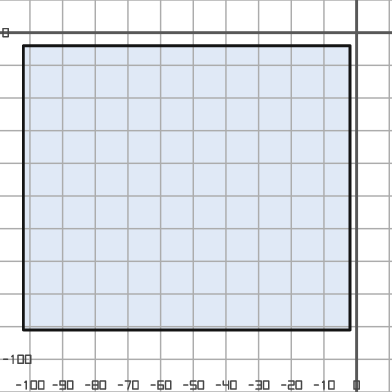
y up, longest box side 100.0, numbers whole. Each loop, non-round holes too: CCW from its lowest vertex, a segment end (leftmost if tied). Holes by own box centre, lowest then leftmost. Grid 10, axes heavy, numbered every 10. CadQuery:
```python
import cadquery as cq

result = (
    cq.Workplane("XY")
    .moveTo(-102.0, -91.0)
    .lineTo(-2.0, -91.0)
    .lineTo(-2.0, -4.0)
    .lineTo(-102.0, -4.0)
    .close()
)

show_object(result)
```